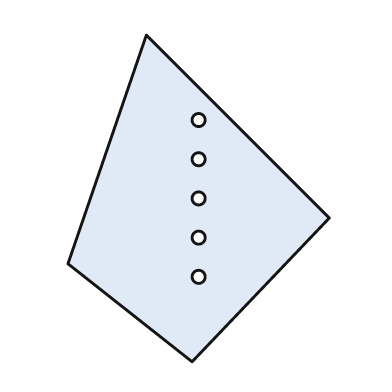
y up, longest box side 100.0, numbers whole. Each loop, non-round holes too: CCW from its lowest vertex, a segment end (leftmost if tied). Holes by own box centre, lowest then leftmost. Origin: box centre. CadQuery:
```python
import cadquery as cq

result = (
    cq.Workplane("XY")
    .moveTo(-2.0, -50.0)
    .lineTo(40.0, -6.0)
    .lineTo(-16.0, 50.0)
    .lineTo(-40.0, -20.0)
    .close()
    .moveTo(0.0, -24.0)
    .circle(2.0)
    .moveTo(0.0, -12.0)
    .circle(2.0)
    .moveTo(0.0, 0.0)
    .circle(2.0)
    .moveTo(0.0, 12.0)
    .circle(2.0)
    .moveTo(0.0, 24.0)
    .circle(2.0)
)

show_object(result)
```